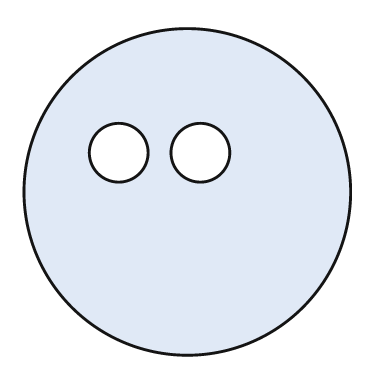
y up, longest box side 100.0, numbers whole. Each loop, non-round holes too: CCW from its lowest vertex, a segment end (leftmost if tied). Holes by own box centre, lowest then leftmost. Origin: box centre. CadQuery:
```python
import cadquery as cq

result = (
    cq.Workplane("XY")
    .moveTo(0.0, 0.0)
    .circle(50.0)
    .moveTo(-21.0, 12.0)
    .circle(9.0)
    .moveTo(4.0, 12.0)
    .circle(9.0)
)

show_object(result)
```